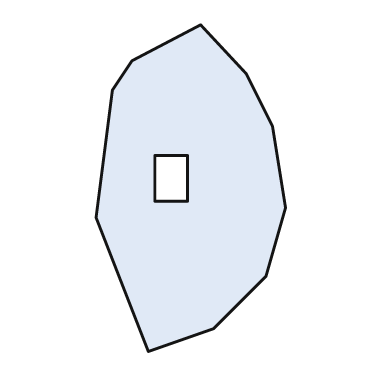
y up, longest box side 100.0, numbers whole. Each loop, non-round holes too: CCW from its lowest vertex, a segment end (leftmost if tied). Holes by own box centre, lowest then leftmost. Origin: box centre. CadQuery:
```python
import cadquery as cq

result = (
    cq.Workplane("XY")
    .moveTo(-13.0, -50.0)
    .lineTo(7.0, -43.0)
    .lineTo(23.0, -27.0)
    .lineTo(29.0, -6.0)
    .lineTo(25.0, 19.0)
    .lineTo(17.0, 35.0)
    .lineTo(3.0, 50.0)
    .lineTo(-18.0, 39.0)
    .lineTo(-24.0, 30.0)
    .lineTo(-29.0, -9.0)
    .close()
    .moveTo(-11.0, -4.0)
    .lineTo(-1.0, -4.0)
    .lineTo(-1.0, 10.0)
    .lineTo(-11.0, 10.0)
    .close()
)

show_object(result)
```